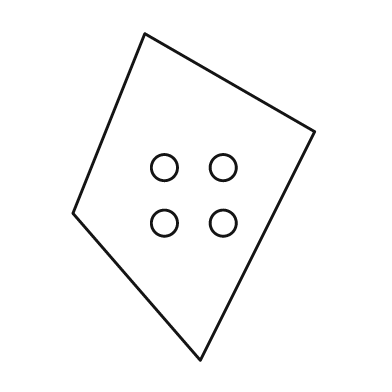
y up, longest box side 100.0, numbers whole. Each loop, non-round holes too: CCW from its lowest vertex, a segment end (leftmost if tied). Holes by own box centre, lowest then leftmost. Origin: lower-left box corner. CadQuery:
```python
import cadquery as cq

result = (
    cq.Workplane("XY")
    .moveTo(39.0, 0.0)
    .lineTo(74.0, 70.0)
    .lineTo(22.0, 100.0)
    .lineTo(0.0, 45.0)
    .close()
    .moveTo(28.0, 42.0)
    .circle(4.0)
    .moveTo(46.0, 42.0)
    .circle(4.0)
    .moveTo(28.0, 59.0)
    .circle(4.0)
    .moveTo(46.0, 59.0)
    .circle(4.0)
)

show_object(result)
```